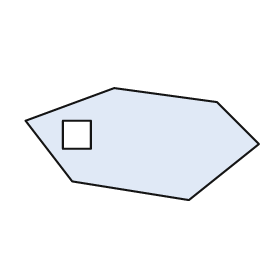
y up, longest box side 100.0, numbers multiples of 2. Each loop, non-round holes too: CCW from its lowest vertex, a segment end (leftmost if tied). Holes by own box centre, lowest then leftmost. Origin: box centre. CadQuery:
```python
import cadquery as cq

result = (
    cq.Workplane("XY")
    .moveTo(20.0, -24.0)
    .lineTo(50.0, 0.0)
    .lineTo(32.0, 18.0)
    .lineTo(-12.0, 24.0)
    .lineTo(-50.0, 10.0)
    .lineTo(-30.0, -16.0)
    .close()
    .moveTo(-34.0, -2.0)
    .lineTo(-22.0, -2.0)
    .lineTo(-22.0, 10.0)
    .lineTo(-34.0, 10.0)
    .close()
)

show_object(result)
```